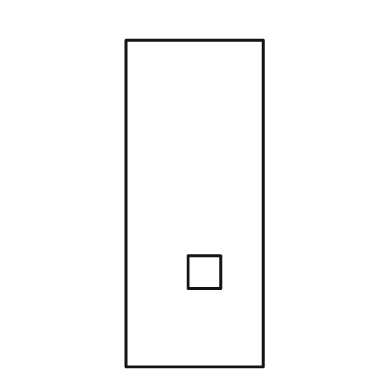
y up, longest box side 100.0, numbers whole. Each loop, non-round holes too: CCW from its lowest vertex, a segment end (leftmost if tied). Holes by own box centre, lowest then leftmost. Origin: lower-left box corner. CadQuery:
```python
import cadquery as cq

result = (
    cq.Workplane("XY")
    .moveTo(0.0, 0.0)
    .lineTo(42.0, 0.0)
    .lineTo(42.0, 100.0)
    .lineTo(0.0, 100.0)
    .close()
    .moveTo(19.0, 24.0)
    .lineTo(29.0, 24.0)
    .lineTo(29.0, 34.0)
    .lineTo(19.0, 34.0)
    .close()
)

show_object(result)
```